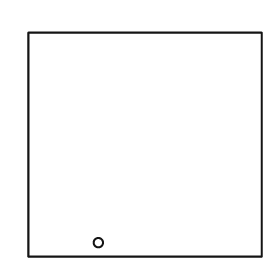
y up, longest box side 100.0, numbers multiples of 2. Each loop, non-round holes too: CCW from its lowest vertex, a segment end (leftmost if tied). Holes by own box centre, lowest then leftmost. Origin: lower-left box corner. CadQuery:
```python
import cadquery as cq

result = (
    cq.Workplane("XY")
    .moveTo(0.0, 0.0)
    .lineTo(100.0, 0.0)
    .lineTo(100.0, 96.0)
    .lineTo(0.0, 96.0)
    .close()
    .moveTo(30.0, 6.0)
    .circle(2.0)
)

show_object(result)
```